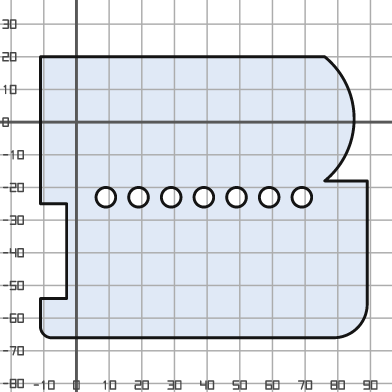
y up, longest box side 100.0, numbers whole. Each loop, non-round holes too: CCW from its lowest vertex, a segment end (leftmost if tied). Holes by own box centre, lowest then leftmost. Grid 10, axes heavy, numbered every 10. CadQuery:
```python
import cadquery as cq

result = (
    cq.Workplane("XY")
    .moveTo(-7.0, -66.0)
    .lineTo(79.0, -66.0)
    .threePointArc((86.0, -63.0), (89.0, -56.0))
    .lineTo(89.0, -18.0)
    .lineTo(76.0, -18.0)
    .threePointArc((85.0, 1.0), (76.0, 20.0))
    .lineTo(-11.0, 20.0)
    .lineTo(-11.0, -25.0)
    .lineTo(-3.0, -25.0)
    .lineTo(-3.0, -54.0)
    .lineTo(-11.0, -54.0)
    .lineTo(-11.0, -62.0)
    .threePointArc((-10.0, -65.0), (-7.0, -66.0))
    .close()
    .moveTo(9.0, -23.0)
    .circle(3.0)
    .moveTo(19.0, -23.0)
    .circle(3.0)
    .moveTo(29.0, -23.0)
    .circle(3.0)
    .moveTo(39.0, -23.0)
    .circle(3.0)
    .moveTo(49.0, -23.0)
    .circle(3.0)
    .moveTo(59.0, -23.0)
    .circle(3.0)
    .moveTo(69.0, -23.0)
    .circle(3.0)
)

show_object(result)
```